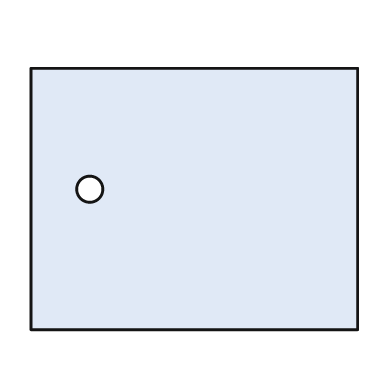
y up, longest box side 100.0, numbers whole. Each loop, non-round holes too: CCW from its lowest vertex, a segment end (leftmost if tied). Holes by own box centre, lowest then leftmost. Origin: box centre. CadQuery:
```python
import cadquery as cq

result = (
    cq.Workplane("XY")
    .moveTo(-50.0, -40.0)
    .lineTo(50.0, -40.0)
    .lineTo(50.0, 40.0)
    .lineTo(-50.0, 40.0)
    .close()
    .moveTo(-32.0, 3.0)
    .circle(4.0)
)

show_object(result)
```